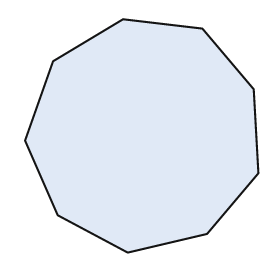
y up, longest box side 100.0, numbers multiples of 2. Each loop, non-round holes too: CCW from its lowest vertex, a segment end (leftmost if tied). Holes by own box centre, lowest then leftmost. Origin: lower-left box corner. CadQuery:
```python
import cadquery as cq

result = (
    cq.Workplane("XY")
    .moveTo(44.0, 0.0)
    .lineTo(78.0, 8.0)
    .lineTo(100.0, 34.0)
    .lineTo(98.0, 70.0)
    .lineTo(76.0, 96.0)
    .lineTo(42.0, 100.0)
    .lineTo(12.0, 82.0)
    .lineTo(0.0, 48.0)
    .lineTo(14.0, 16.0)
    .close()
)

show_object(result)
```